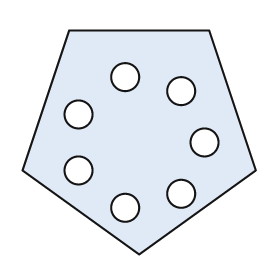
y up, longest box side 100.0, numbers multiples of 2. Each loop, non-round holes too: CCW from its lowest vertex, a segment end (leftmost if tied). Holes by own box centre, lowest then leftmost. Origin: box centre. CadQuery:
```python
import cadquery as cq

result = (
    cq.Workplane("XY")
    .moveTo(0.0, -48.0)
    .lineTo(50.0, -12.0)
    .lineTo(30.0, 48.0)
    .lineTo(-30.0, 48.0)
    .lineTo(-50.0, -12.0)
    .close()
    .moveTo(-6.0, -28.0)
    .circle(6.0)
    .moveTo(18.0, -22.0)
    .circle(6.0)
    .moveTo(-26.0, -12.0)
    .circle(6.0)
    .moveTo(28.0, 0.0)
    .circle(6.0)
    .moveTo(-26.0, 12.0)
    .circle(6.0)
    .moveTo(18.0, 22.0)
    .circle(6.0)
    .moveTo(-6.0, 28.0)
    .circle(6.0)
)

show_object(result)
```